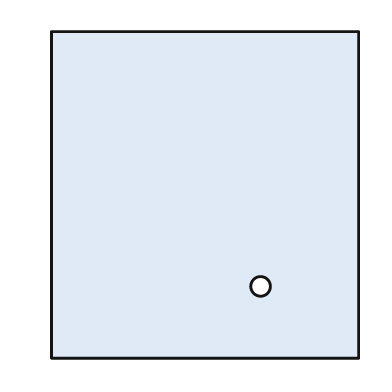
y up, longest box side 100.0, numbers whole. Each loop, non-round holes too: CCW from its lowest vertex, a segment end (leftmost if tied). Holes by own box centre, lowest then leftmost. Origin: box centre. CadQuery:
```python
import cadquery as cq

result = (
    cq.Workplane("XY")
    .moveTo(-47.0, -50.0)
    .lineTo(47.0, -50.0)
    .lineTo(47.0, 50.0)
    .lineTo(-47.0, 50.0)
    .close()
    .moveTo(17.0, -28.0)
    .circle(3.0)
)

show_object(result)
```